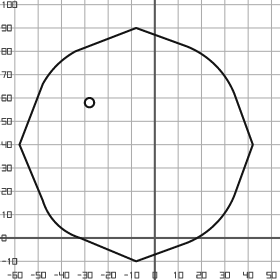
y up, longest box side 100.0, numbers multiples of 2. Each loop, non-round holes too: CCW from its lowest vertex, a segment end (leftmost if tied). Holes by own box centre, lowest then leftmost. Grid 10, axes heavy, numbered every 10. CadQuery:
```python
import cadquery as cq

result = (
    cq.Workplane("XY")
    .moveTo(-8.0, -10.0)
    .lineTo(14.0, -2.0)
    .threePointArc((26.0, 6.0), (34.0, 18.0))
    .lineTo(42.0, 40.0)
    .lineTo(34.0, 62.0)
    .threePointArc((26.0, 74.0), (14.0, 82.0))
    .lineTo(-8.0, 90.0)
    .lineTo(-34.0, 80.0)
    .threePointArc((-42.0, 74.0), (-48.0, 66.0))
    .lineTo(-58.0, 40.0)
    .lineTo(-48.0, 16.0)
    .threePointArc((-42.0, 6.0), (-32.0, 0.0))
    .close()
    .moveTo(-28.0, 58.0)
    .circle(2.0)
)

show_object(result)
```